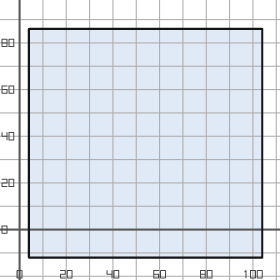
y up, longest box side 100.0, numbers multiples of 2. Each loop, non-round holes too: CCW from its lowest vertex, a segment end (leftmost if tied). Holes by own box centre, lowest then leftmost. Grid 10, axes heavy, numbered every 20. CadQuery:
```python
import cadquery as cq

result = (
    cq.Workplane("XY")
    .moveTo(4.0, -12.0)
    .lineTo(104.0, -12.0)
    .lineTo(104.0, 86.0)
    .lineTo(4.0, 86.0)
    .close()
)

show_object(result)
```